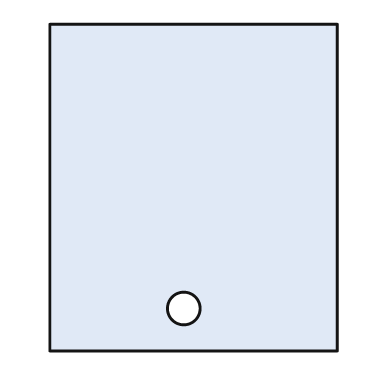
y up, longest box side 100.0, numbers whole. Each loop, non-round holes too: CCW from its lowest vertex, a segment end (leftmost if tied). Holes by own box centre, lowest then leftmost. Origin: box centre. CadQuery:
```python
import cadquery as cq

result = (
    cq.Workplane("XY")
    .moveTo(-44.0, -50.0)
    .lineTo(44.0, -50.0)
    .lineTo(44.0, 50.0)
    .lineTo(-44.0, 50.0)
    .close()
    .moveTo(-3.0, -37.0)
    .circle(5.0)
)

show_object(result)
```